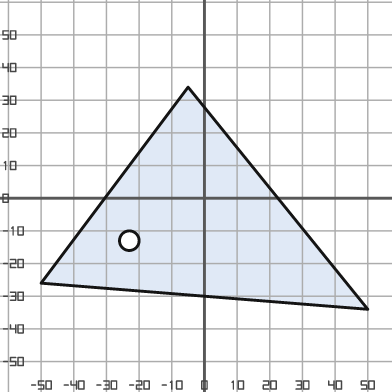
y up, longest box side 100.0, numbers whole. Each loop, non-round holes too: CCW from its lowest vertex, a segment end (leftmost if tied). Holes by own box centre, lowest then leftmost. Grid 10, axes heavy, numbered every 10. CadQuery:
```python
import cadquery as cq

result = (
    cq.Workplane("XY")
    .moveTo(50.0, -34.0)
    .lineTo(-5.0, 34.0)
    .lineTo(-50.0, -26.0)
    .close()
    .moveTo(-23.0, -13.0)
    .circle(3.0)
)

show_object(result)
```